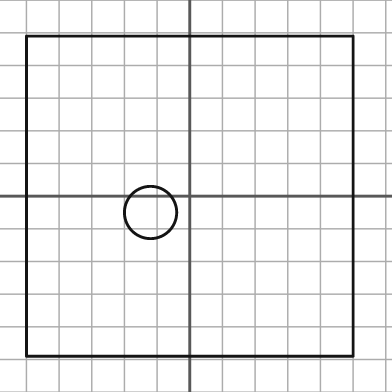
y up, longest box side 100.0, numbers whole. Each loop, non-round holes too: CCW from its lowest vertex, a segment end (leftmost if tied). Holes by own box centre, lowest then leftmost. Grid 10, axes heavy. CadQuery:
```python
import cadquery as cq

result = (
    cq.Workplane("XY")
    .moveTo(-50.0, -49.0)
    .lineTo(50.0, -49.0)
    .lineTo(50.0, 49.0)
    .lineTo(-50.0, 49.0)
    .close()
    .moveTo(-12.0, -5.0)
    .circle(8.0)
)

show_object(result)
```